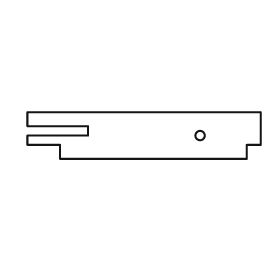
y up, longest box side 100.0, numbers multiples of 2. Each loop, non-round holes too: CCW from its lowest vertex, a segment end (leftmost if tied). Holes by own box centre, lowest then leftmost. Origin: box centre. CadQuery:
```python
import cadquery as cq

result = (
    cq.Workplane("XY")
    .moveTo(-36.0, -10.0)
    .lineTo(44.0, -10.0)
    .lineTo(44.0, -4.0)
    .lineTo(50.0, -4.0)
    .lineTo(50.0, 10.0)
    .lineTo(-50.0, 10.0)
    .lineTo(-50.0, 4.0)
    .lineTo(-24.0, 4.0)
    .lineTo(-24.0, 0.0)
    .lineTo(-50.0, 0.0)
    .lineTo(-50.0, -4.0)
    .lineTo(-36.0, -4.0)
    .close()
    .moveTo(24.0, 0.0)
    .circle(2.0)
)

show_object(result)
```